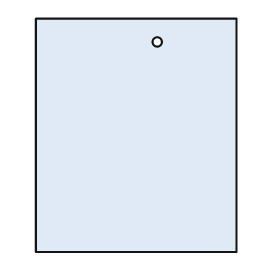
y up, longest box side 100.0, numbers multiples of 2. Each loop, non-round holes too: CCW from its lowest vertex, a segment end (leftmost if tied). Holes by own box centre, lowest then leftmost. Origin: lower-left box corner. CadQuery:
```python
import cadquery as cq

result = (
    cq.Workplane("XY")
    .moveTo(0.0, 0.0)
    .lineTo(86.0, 0.0)
    .lineTo(86.0, 100.0)
    .lineTo(0.0, 100.0)
    .close()
    .moveTo(52.0, 90.0)
    .circle(2.0)
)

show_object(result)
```